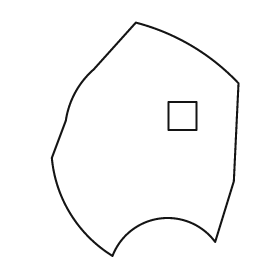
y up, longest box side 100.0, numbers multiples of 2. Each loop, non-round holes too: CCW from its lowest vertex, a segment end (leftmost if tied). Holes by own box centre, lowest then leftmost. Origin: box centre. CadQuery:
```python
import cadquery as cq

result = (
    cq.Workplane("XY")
    .moveTo(-14.0, -50.0)
    .threePointArc((6.0, -34.0), (30.0, -44.0))
    .lineTo(38.0, -18.0)
    .lineTo(40.0, 24.0)
    .threePointArc((20.0, 40.0), (-4.0, 50.0))
    .lineTo(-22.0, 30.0)
    .threePointArc((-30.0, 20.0), (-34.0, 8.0))
    .lineTo(-40.0, -8.0)
    .threePointArc((-32.0, -32.0), (-14.0, -50.0))
    .close()
    .moveTo(10.0, 4.0)
    .lineTo(22.0, 4.0)
    .lineTo(22.0, 16.0)
    .lineTo(10.0, 16.0)
    .close()
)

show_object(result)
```